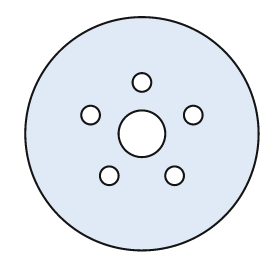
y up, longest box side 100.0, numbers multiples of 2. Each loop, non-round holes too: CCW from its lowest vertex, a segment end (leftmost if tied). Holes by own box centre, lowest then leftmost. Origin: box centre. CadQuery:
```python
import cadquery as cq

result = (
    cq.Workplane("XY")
    .moveTo(0.0, 0.0)
    .circle(50.0)
    .moveTo(-14.0, -18.0)
    .circle(4.0)
    .moveTo(14.0, -18.0)
    .circle(4.0)
    .moveTo(0.0, 0.0)
    .circle(10.0)
    .moveTo(-22.0, 8.0)
    .circle(4.0)
    .moveTo(22.0, 8.0)
    .circle(4.0)
    .moveTo(0.0, 22.0)
    .circle(4.0)
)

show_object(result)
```